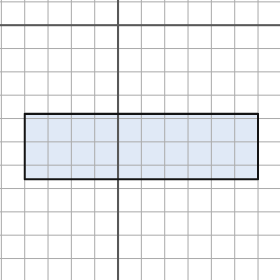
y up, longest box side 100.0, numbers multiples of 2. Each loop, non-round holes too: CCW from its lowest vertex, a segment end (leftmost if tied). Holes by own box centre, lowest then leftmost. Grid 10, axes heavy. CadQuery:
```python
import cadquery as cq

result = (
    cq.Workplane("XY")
    .moveTo(-40.0, -66.0)
    .lineTo(60.0, -66.0)
    .lineTo(60.0, -38.0)
    .lineTo(-40.0, -38.0)
    .close()
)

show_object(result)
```